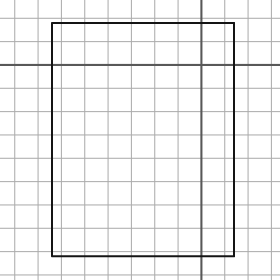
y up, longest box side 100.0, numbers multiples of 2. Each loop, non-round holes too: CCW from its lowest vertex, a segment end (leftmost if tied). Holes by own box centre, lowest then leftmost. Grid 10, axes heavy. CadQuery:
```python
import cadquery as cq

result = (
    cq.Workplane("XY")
    .moveTo(-64.0, -82.0)
    .lineTo(14.0, -82.0)
    .lineTo(14.0, 18.0)
    .lineTo(-64.0, 18.0)
    .close()
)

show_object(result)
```